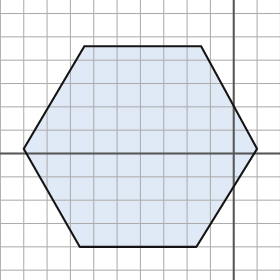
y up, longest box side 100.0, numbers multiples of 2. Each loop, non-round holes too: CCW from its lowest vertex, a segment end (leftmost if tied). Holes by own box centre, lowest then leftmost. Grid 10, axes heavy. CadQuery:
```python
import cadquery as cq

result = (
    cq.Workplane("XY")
    .moveTo(-66.0, -40.0)
    .lineTo(-16.0, -40.0)
    .lineTo(10.0, 2.0)
    .lineTo(-14.0, 46.0)
    .lineTo(-64.0, 46.0)
    .lineTo(-90.0, 2.0)
    .close()
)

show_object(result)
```